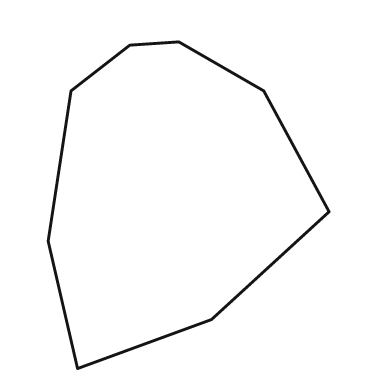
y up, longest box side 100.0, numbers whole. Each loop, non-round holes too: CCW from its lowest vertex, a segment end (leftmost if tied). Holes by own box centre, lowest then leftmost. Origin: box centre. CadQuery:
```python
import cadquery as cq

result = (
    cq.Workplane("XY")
    .moveTo(-34.0, -50.0)
    .lineTo(7.0, -35.0)
    .lineTo(43.0, -2.0)
    .lineTo(23.0, 35.0)
    .lineTo(-3.0, 50.0)
    .lineTo(-18.0, 49.0)
    .lineTo(-36.0, 35.0)
    .lineTo(-43.0, -11.0)
    .close()
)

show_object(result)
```